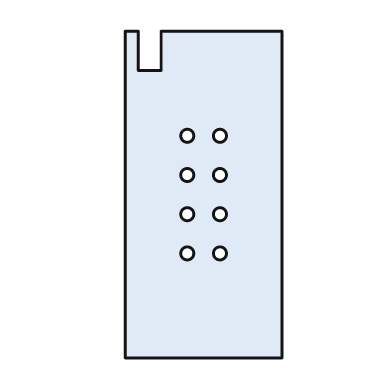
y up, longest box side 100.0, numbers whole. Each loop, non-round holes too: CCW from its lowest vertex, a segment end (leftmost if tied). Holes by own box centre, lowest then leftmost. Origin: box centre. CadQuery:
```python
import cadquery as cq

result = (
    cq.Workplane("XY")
    .moveTo(-24.0, -50.0)
    .lineTo(24.0, -50.0)
    .lineTo(24.0, 50.0)
    .lineTo(-13.0, 50.0)
    .lineTo(-13.0, 38.0)
    .lineTo(-20.0, 38.0)
    .lineTo(-20.0, 50.0)
    .lineTo(-24.0, 50.0)
    .close()
    .moveTo(-5.0, -18.0)
    .circle(2.0)
    .moveTo(5.0, -18.0)
    .circle(2.0)
    .moveTo(-5.0, -6.0)
    .circle(2.0)
    .moveTo(5.0, -6.0)
    .circle(2.0)
    .moveTo(-5.0, 6.0)
    .circle(2.0)
    .moveTo(5.0, 6.0)
    .circle(2.0)
    .moveTo(-5.0, 18.0)
    .circle(2.0)
    .moveTo(5.0, 18.0)
    .circle(2.0)
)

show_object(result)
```